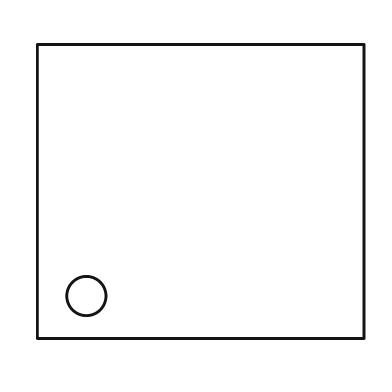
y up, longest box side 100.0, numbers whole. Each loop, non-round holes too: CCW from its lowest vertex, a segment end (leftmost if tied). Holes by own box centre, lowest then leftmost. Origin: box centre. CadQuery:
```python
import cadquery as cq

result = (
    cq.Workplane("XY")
    .moveTo(-50.0, -45.0)
    .lineTo(50.0, -45.0)
    .lineTo(50.0, 45.0)
    .lineTo(-50.0, 45.0)
    .close()
    .moveTo(-35.0, -32.0)
    .circle(6.0)
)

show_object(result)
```